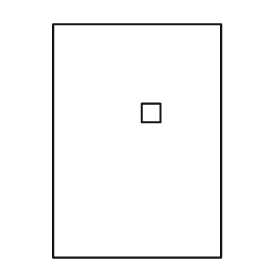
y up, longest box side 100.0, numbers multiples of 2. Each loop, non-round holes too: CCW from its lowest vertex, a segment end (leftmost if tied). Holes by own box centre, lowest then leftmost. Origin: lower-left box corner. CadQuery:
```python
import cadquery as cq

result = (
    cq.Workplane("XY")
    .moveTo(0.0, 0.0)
    .lineTo(72.0, 0.0)
    .lineTo(72.0, 100.0)
    .lineTo(0.0, 100.0)
    .close()
    .moveTo(38.0, 58.0)
    .lineTo(46.0, 58.0)
    .lineTo(46.0, 66.0)
    .lineTo(38.0, 66.0)
    .close()
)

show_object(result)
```